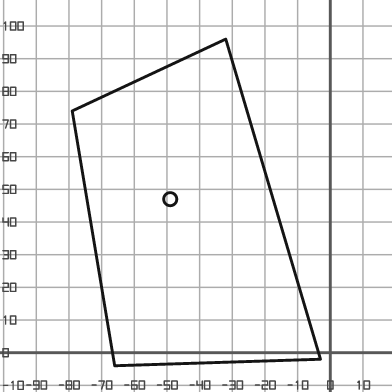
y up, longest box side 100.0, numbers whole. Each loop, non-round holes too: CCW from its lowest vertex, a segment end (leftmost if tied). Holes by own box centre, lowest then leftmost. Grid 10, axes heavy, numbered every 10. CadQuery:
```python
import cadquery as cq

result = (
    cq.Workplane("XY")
    .moveTo(-66.0, -4.0)
    .lineTo(-3.0, -2.0)
    .lineTo(-32.0, 96.0)
    .lineTo(-79.0, 74.0)
    .close()
    .moveTo(-49.0, 47.0)
    .circle(2.0)
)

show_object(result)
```